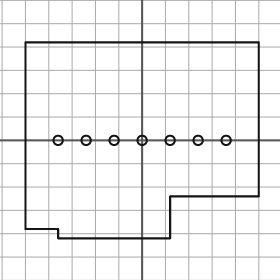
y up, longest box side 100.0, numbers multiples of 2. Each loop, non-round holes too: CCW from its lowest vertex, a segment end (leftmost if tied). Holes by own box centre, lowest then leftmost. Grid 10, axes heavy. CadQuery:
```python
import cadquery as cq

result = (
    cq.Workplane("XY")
    .moveTo(-36.0, -42.0)
    .lineTo(12.0, -42.0)
    .lineTo(12.0, -24.0)
    .lineTo(50.0, -24.0)
    .lineTo(50.0, 42.0)
    .lineTo(-50.0, 42.0)
    .lineTo(-50.0, -38.0)
    .lineTo(-36.0, -38.0)
    .close()
    .moveTo(-36.0, 0.0)
    .circle(2.0)
    .moveTo(-24.0, 0.0)
    .circle(2.0)
    .moveTo(-12.0, 0.0)
    .circle(2.0)
    .moveTo(0.0, 0.0)
    .circle(2.0)
    .moveTo(12.0, 0.0)
    .circle(2.0)
    .moveTo(24.0, 0.0)
    .circle(2.0)
    .moveTo(36.0, 0.0)
    .circle(2.0)
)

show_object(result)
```